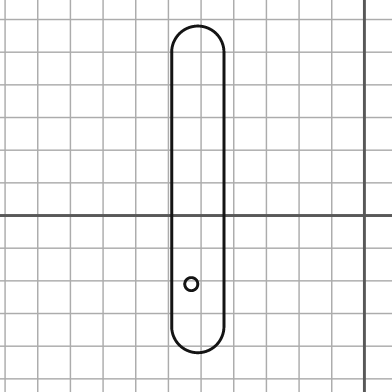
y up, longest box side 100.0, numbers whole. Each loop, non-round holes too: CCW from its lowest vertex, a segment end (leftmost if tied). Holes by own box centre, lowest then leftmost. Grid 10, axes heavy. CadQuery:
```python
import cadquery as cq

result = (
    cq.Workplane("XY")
    .moveTo(-59.0, -34.0)
    .threePointArc((-51.0, -42.0), (-43.0, -34.0))
    .lineTo(-43.0, 50.0)
    .threePointArc((-51.0, 58.0), (-59.0, 50.0))
    .close()
    .moveTo(-53.0, -21.0)
    .circle(2.0)
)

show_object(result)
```